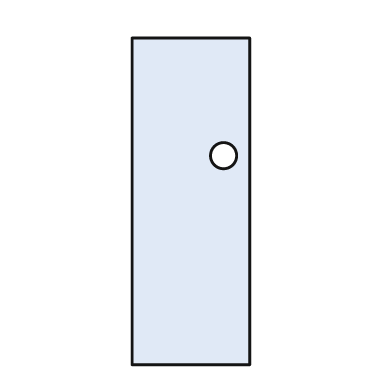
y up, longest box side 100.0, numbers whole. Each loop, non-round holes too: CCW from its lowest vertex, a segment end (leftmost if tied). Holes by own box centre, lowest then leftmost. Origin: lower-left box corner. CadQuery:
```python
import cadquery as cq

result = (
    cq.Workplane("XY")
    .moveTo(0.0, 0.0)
    .lineTo(36.0, 0.0)
    .lineTo(36.0, 100.0)
    .lineTo(0.0, 100.0)
    .close()
    .moveTo(28.0, 64.0)
    .circle(4.0)
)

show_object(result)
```